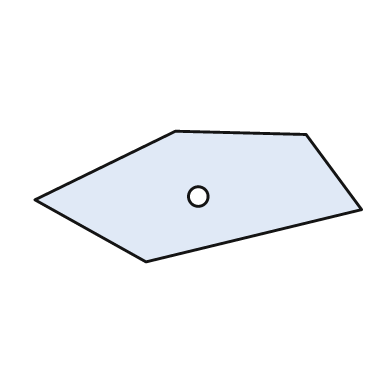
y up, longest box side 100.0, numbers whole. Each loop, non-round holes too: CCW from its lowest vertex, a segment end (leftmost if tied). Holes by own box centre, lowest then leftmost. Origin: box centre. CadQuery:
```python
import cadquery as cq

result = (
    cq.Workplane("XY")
    .moveTo(-16.0, -20.0)
    .lineTo(50.0, -4.0)
    .lineTo(33.0, 19.0)
    .lineTo(-7.0, 20.0)
    .lineTo(-50.0, -1.0)
    .close()
    .moveTo(0.0, 0.0)
    .circle(3.0)
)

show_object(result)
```